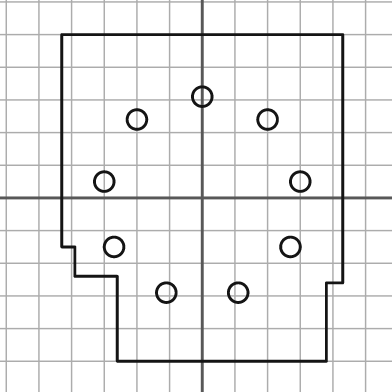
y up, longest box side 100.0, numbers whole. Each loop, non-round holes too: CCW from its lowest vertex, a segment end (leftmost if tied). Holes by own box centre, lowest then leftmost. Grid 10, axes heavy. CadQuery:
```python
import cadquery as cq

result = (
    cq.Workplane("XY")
    .moveTo(-26.0, -50.0)
    .lineTo(38.0, -50.0)
    .lineTo(38.0, -26.0)
    .lineTo(43.0, -26.0)
    .lineTo(43.0, 50.0)
    .lineTo(-43.0, 50.0)
    .lineTo(-43.0, -15.0)
    .lineTo(-39.0, -15.0)
    .lineTo(-39.0, -24.0)
    .lineTo(-26.0, -24.0)
    .close()
    .moveTo(-11.0, -29.0)
    .circle(3.0)
    .moveTo(11.0, -29.0)
    .circle(3.0)
    .moveTo(-27.0, -15.0)
    .circle(3.0)
    .moveTo(27.0, -15.0)
    .circle(3.0)
    .moveTo(-30.0, 5.0)
    .circle(3.0)
    .moveTo(30.0, 5.0)
    .circle(3.0)
    .moveTo(-20.0, 24.0)
    .circle(3.0)
    .moveTo(20.0, 24.0)
    .circle(3.0)
    .moveTo(0.0, 31.0)
    .circle(3.0)
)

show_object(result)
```